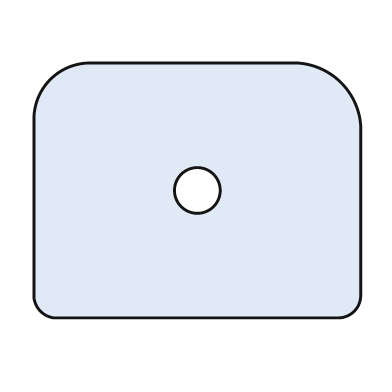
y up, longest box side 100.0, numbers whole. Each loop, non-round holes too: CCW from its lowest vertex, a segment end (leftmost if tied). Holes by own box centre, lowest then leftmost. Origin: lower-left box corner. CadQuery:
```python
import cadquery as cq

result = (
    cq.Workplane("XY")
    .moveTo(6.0, 0.0)
    .lineTo(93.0, 0.0)
    .threePointArc((98.0, 2.0), (100.0, 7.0))
    .lineTo(100.0, 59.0)
    .threePointArc((94.0, 72.0), (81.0, 78.0))
    .lineTo(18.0, 78.0)
    .threePointArc((5.0, 73.0), (0.0, 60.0))
    .lineTo(0.0, 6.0)
    .threePointArc((2.0, 2.0), (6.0, 0.0))
    .close()
    .moveTo(50.0, 39.0)
    .circle(7.0)
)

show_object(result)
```